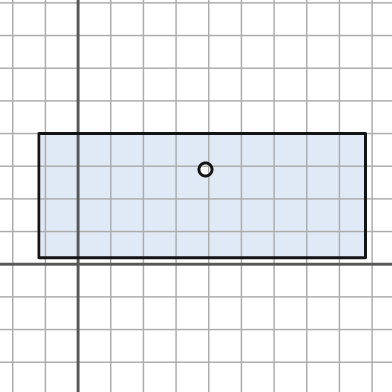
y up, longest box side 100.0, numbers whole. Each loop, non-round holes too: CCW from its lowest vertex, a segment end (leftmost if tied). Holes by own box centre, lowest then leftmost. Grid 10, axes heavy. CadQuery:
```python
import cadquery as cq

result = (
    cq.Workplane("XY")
    .moveTo(-12.0, 2.0)
    .lineTo(88.0, 2.0)
    .lineTo(88.0, 40.0)
    .lineTo(-12.0, 40.0)
    .close()
    .moveTo(39.0, 29.0)
    .circle(2.0)
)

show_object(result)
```